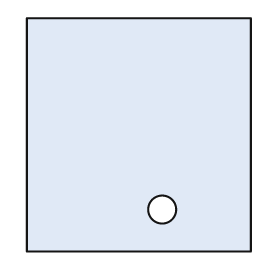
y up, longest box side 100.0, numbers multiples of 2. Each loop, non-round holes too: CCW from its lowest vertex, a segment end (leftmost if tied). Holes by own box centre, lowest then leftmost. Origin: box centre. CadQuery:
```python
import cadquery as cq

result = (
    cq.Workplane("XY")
    .moveTo(-48.0, -50.0)
    .lineTo(48.0, -50.0)
    .lineTo(48.0, 50.0)
    .lineTo(-48.0, 50.0)
    .close()
    .moveTo(10.0, -32.0)
    .circle(6.0)
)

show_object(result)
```